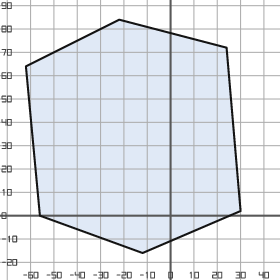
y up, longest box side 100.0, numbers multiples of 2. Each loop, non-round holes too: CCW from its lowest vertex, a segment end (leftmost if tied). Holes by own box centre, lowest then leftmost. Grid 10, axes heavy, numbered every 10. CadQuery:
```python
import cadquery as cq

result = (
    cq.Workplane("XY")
    .moveTo(-12.0, -16.0)
    .lineTo(30.0, 2.0)
    .lineTo(24.0, 72.0)
    .lineTo(-22.0, 84.0)
    .lineTo(-62.0, 64.0)
    .lineTo(-56.0, 0.0)
    .close()
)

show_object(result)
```